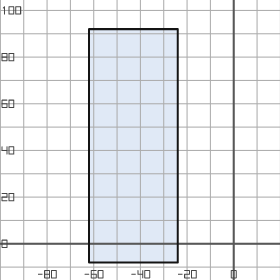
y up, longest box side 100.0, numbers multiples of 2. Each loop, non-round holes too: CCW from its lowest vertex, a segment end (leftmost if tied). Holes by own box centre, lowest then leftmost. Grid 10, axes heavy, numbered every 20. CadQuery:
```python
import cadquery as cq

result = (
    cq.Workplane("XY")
    .moveTo(-62.0, -8.0)
    .lineTo(-24.0, -8.0)
    .lineTo(-24.0, 92.0)
    .lineTo(-62.0, 92.0)
    .close()
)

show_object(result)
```